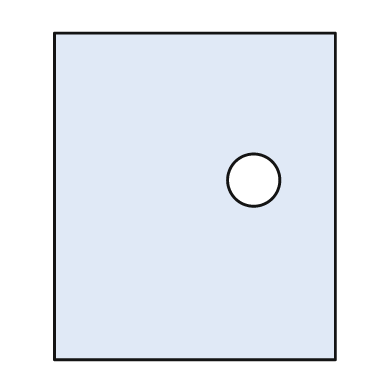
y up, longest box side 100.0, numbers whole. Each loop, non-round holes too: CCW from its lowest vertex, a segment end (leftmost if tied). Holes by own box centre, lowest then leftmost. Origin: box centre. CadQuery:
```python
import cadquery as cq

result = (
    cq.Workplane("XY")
    .moveTo(-43.0, -50.0)
    .lineTo(43.0, -50.0)
    .lineTo(43.0, 50.0)
    .lineTo(-43.0, 50.0)
    .close()
    .moveTo(18.0, 5.0)
    .circle(8.0)
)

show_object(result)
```